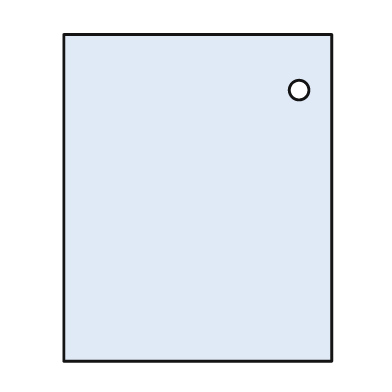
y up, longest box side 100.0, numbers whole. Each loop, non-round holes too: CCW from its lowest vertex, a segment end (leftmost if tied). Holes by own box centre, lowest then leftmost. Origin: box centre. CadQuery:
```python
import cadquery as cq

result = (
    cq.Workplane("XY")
    .moveTo(-41.0, -50.0)
    .lineTo(41.0, -50.0)
    .lineTo(41.0, 50.0)
    .lineTo(-41.0, 50.0)
    .close()
    .moveTo(31.0, 33.0)
    .circle(3.0)
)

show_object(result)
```